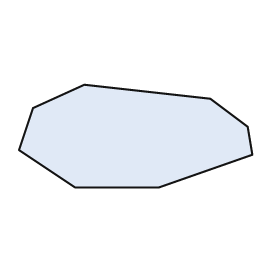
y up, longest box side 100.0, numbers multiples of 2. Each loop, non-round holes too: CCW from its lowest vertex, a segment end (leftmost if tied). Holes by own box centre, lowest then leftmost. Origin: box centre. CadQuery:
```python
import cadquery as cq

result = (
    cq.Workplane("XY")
    .moveTo(-26.0, -22.0)
    .lineTo(10.0, -22.0)
    .lineTo(50.0, -8.0)
    .lineTo(48.0, 4.0)
    .lineTo(32.0, 16.0)
    .lineTo(-22.0, 22.0)
    .lineTo(-44.0, 12.0)
    .lineTo(-50.0, -6.0)
    .close()
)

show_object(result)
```